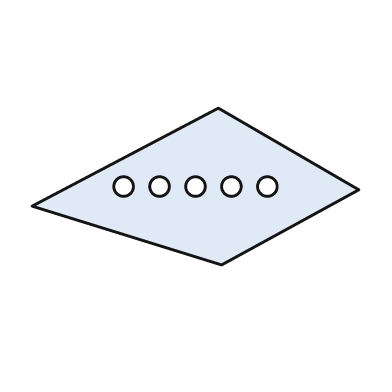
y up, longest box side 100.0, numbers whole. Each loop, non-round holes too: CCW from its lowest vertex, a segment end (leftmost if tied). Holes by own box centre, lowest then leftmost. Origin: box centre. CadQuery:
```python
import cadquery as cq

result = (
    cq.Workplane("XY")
    .moveTo(8.0, -24.0)
    .lineTo(50.0, -1.0)
    .lineTo(7.0, 24.0)
    .lineTo(-50.0, -6.0)
    .close()
    .moveTo(-22.0, 0.0)
    .circle(3.0)
    .moveTo(-11.0, 0.0)
    .circle(3.0)
    .moveTo(0.0, 0.0)
    .circle(3.0)
    .moveTo(11.0, 0.0)
    .circle(3.0)
    .moveTo(22.0, 0.0)
    .circle(3.0)
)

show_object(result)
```